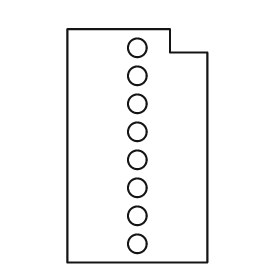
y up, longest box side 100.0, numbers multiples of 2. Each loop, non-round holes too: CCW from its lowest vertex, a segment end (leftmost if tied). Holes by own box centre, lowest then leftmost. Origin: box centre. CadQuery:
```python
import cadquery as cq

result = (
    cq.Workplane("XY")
    .moveTo(-30.0, -50.0)
    .lineTo(30.0, -50.0)
    .lineTo(30.0, 40.0)
    .lineTo(14.0, 40.0)
    .lineTo(14.0, 50.0)
    .lineTo(-30.0, 50.0)
    .close()
    .moveTo(0.0, -42.0)
    .circle(4.0)
    .moveTo(0.0, -30.0)
    .circle(4.0)
    .moveTo(0.0, -18.0)
    .circle(4.0)
    .moveTo(0.0, -6.0)
    .circle(4.0)
    .moveTo(0.0, 6.0)
    .circle(4.0)
    .moveTo(0.0, 18.0)
    .circle(4.0)
    .moveTo(0.0, 30.0)
    .circle(4.0)
    .moveTo(0.0, 42.0)
    .circle(4.0)
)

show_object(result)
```